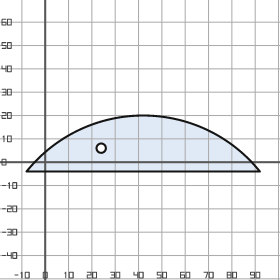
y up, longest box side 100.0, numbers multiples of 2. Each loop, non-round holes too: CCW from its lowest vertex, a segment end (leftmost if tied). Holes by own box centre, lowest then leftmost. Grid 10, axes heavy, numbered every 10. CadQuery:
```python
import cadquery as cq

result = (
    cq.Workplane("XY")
    .moveTo(-8.0, -4.0)
    .lineTo(92.0, -4.0)
    .threePointArc((42.0, 20.0), (-8.0, -4.0))
    .close()
    .moveTo(24.0, 6.0)
    .circle(2.0)
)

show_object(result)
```